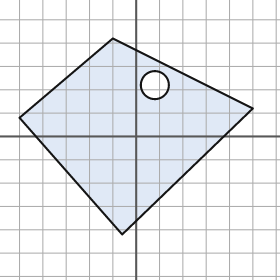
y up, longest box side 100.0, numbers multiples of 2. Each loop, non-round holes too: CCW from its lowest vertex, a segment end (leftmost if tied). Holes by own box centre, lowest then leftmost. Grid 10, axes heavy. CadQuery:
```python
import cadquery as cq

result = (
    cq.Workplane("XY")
    .moveTo(-6.0, -42.0)
    .lineTo(50.0, 12.0)
    .lineTo(-10.0, 42.0)
    .lineTo(-50.0, 8.0)
    .close()
    .moveTo(8.0, 22.0)
    .circle(6.0)
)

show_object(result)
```